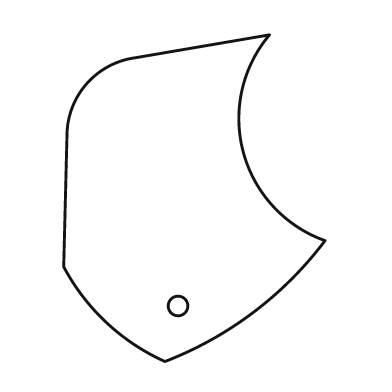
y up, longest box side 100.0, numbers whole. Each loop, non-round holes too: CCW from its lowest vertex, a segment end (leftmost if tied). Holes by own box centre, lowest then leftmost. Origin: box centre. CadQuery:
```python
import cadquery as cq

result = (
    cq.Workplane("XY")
    .moveTo(-9.0, -50.0)
    .threePointArc((18.0, -35.0), (40.0, -13.0))
    .threePointArc((15.0, 14.0), (23.0, 50.0))
    .lineTo(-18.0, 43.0)
    .threePointArc((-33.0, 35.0), (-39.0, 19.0))
    .lineTo(-40.0, -21.0)
    .threePointArc((-27.0, -38.0), (-9.0, -50.0))
    .close()
    .moveTo(-5.0, -33.0)
    .circle(3.0)
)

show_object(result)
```